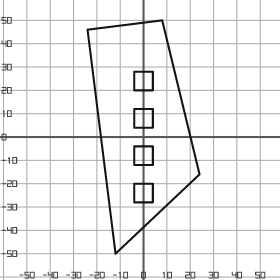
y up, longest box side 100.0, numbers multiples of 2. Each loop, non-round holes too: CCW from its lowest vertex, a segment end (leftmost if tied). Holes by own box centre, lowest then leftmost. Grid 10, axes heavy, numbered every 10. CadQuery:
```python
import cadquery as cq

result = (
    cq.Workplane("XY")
    .moveTo(-12.0, -50.0)
    .lineTo(24.0, -16.0)
    .lineTo(8.0, 50.0)
    .lineTo(-24.0, 46.0)
    .close()
    .moveTo(-4.0, -28.0)
    .lineTo(4.0, -28.0)
    .lineTo(4.0, -20.0)
    .lineTo(-4.0, -20.0)
    .close()
    .moveTo(-4.0, -12.0)
    .lineTo(4.0, -12.0)
    .lineTo(4.0, -4.0)
    .lineTo(-4.0, -4.0)
    .close()
    .moveTo(-4.0, 4.0)
    .lineTo(4.0, 4.0)
    .lineTo(4.0, 12.0)
    .lineTo(-4.0, 12.0)
    .close()
    .moveTo(-4.0, 20.0)
    .lineTo(4.0, 20.0)
    .lineTo(4.0, 28.0)
    .lineTo(-4.0, 28.0)
    .close()
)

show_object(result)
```